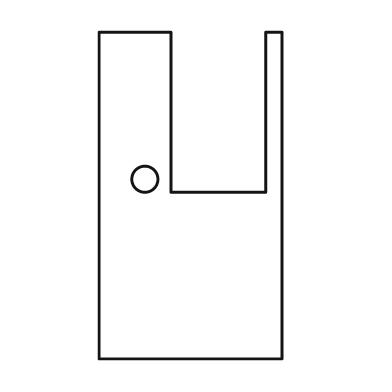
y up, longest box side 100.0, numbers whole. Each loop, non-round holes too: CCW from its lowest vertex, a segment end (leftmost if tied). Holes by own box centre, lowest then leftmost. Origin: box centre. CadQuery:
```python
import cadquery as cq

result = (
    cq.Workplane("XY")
    .moveTo(-28.0, -50.0)
    .lineTo(28.0, -50.0)
    .lineTo(28.0, 50.0)
    .lineTo(23.0, 50.0)
    .lineTo(23.0, 1.0)
    .lineTo(-6.0, 1.0)
    .lineTo(-6.0, 50.0)
    .lineTo(-28.0, 50.0)
    .close()
    .moveTo(-14.0, 5.0)
    .circle(4.0)
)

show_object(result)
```